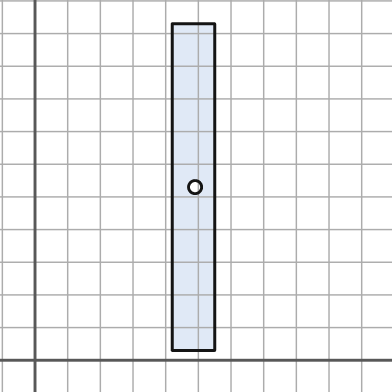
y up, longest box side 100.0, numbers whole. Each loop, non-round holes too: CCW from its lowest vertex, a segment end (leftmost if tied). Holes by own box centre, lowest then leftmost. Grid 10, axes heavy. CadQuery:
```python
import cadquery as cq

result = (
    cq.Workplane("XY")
    .moveTo(42.0, 3.0)
    .lineTo(55.0, 3.0)
    .lineTo(55.0, 103.0)
    .lineTo(42.0, 103.0)
    .close()
    .moveTo(49.0, 53.0)
    .circle(2.0)
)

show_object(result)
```